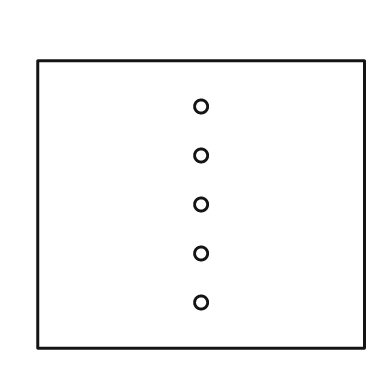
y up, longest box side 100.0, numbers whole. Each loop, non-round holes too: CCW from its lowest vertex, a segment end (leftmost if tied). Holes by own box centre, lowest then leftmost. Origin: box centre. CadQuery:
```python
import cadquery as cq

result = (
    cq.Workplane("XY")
    .moveTo(-50.0, -44.0)
    .lineTo(50.0, -44.0)
    .lineTo(50.0, 44.0)
    .lineTo(-50.0, 44.0)
    .close()
    .moveTo(0.0, -30.0)
    .circle(2.0)
    .moveTo(0.0, -15.0)
    .circle(2.0)
    .moveTo(0.0, 0.0)
    .circle(2.0)
    .moveTo(0.0, 15.0)
    .circle(2.0)
    .moveTo(0.0, 30.0)
    .circle(2.0)
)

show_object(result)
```